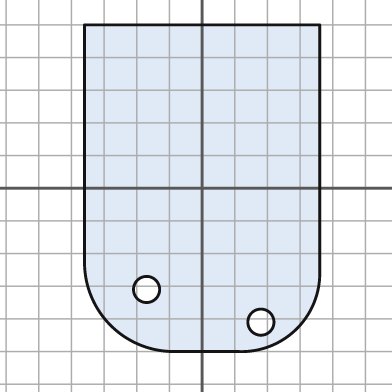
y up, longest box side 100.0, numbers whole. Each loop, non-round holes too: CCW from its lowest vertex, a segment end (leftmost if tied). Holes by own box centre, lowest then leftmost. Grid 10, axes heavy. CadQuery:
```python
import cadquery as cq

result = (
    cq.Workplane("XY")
    .moveTo(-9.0, -50.0)
    .lineTo(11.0, -50.0)
    .threePointArc((29.0, -43.0), (36.0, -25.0))
    .lineTo(36.0, 50.0)
    .lineTo(-36.0, 50.0)
    .lineTo(-36.0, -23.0)
    .threePointArc((-28.0, -42.0), (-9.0, -50.0))
    .close()
    .moveTo(18.0, -41.0)
    .circle(4.0)
    .moveTo(-17.0, -31.0)
    .circle(4.0)
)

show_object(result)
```